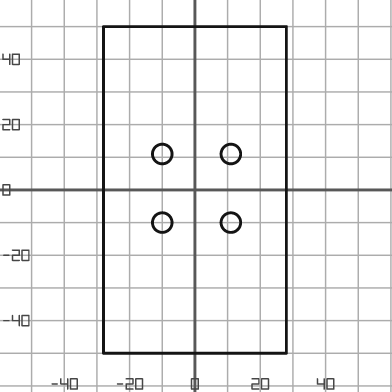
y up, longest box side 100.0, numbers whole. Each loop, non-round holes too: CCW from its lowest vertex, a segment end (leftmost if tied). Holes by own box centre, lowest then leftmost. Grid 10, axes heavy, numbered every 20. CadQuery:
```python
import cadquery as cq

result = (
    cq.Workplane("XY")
    .moveTo(-28.0, -50.0)
    .lineTo(28.0, -50.0)
    .lineTo(28.0, 50.0)
    .lineTo(-28.0, 50.0)
    .close()
    .moveTo(-10.0, -10.0)
    .circle(3.0)
    .moveTo(11.0, -10.0)
    .circle(3.0)
    .moveTo(-10.0, 11.0)
    .circle(3.0)
    .moveTo(11.0, 11.0)
    .circle(3.0)
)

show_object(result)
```